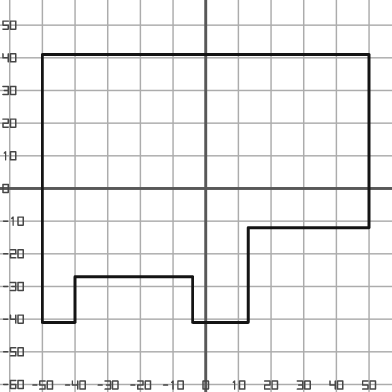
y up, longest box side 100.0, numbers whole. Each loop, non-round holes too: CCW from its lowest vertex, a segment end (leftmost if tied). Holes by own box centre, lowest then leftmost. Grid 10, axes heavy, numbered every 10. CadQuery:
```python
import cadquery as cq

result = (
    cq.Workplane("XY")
    .moveTo(-50.0, -41.0)
    .lineTo(-40.0, -41.0)
    .lineTo(-40.0, -27.0)
    .lineTo(-4.0, -27.0)
    .lineTo(-4.0, -41.0)
    .lineTo(13.0, -41.0)
    .lineTo(13.0, -12.0)
    .lineTo(50.0, -12.0)
    .lineTo(50.0, 41.0)
    .lineTo(-50.0, 41.0)
    .close()
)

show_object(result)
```